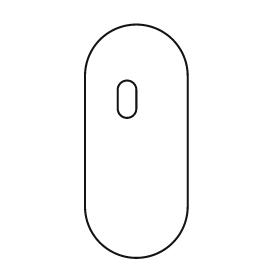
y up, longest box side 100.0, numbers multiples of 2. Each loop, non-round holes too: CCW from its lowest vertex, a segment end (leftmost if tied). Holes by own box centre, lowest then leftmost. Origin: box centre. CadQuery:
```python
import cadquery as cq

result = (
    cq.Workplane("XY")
    .moveTo(-22.0, -28.0)
    .threePointArc((0.0, -50.0), (22.0, -28.0))
    .lineTo(22.0, 28.0)
    .threePointArc((0.0, 50.0), (-22.0, 28.0))
    .close()
    .moveTo(-8.0, 14.0)
    .threePointArc((-4.0, 10.0), (0.0, 14.0))
    .lineTo(0.0, 22.0)
    .threePointArc((-4.0, 26.0), (-8.0, 22.0))
    .close()
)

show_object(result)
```